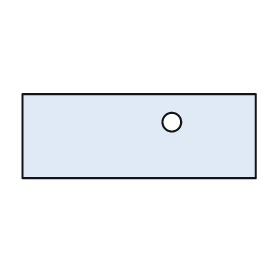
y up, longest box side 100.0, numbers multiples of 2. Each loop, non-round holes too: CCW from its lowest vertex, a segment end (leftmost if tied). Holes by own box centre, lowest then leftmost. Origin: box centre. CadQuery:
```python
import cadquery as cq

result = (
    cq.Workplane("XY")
    .moveTo(-50.0, -18.0)
    .lineTo(50.0, -18.0)
    .lineTo(50.0, 18.0)
    .lineTo(-50.0, 18.0)
    .close()
    .moveTo(14.0, 6.0)
    .circle(4.0)
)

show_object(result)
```